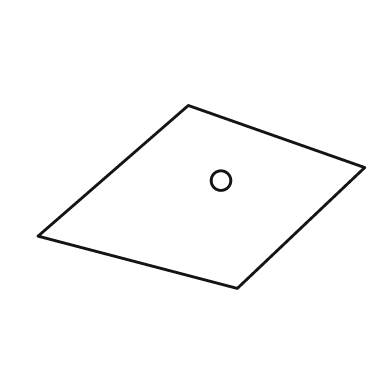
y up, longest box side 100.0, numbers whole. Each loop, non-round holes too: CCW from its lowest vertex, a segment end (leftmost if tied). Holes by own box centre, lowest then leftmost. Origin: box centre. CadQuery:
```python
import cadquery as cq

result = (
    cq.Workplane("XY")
    .moveTo(11.0, -28.0)
    .lineTo(50.0, 9.0)
    .lineTo(-4.0, 28.0)
    .lineTo(-50.0, -12.0)
    .close()
    .moveTo(6.0, 5.0)
    .circle(3.0)
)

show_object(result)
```